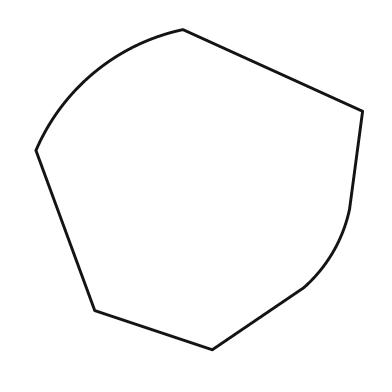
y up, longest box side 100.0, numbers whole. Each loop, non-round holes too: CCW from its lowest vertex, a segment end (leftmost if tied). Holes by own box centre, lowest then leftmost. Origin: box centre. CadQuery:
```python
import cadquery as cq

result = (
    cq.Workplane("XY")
    .moveTo(4.0, -49.0)
    .lineTo(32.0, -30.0)
    .threePointArc((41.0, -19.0), (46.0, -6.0))
    .lineTo(50.0, 24.0)
    .lineTo(-5.0, 49.0)
    .threePointArc((-32.0, 36.0), (-50.0, 12.0))
    .lineTo(-32.0, -37.0)
    .close()
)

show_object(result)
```